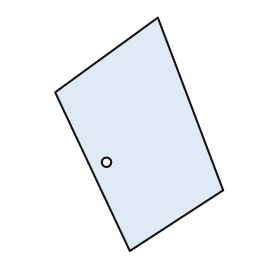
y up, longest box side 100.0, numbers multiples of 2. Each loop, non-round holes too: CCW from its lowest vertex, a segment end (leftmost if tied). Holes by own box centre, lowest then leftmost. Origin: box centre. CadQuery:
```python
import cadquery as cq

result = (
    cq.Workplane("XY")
    .moveTo(-4.0, -50.0)
    .lineTo(36.0, -24.0)
    .lineTo(8.0, 50.0)
    .lineTo(-36.0, 18.0)
    .close()
    .moveTo(-14.0, -12.0)
    .circle(2.0)
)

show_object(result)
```